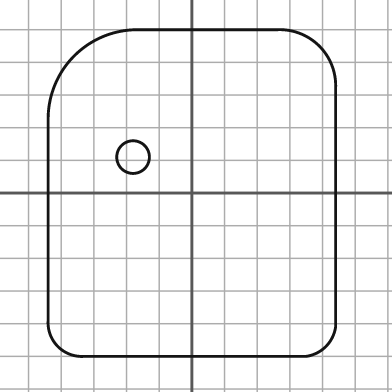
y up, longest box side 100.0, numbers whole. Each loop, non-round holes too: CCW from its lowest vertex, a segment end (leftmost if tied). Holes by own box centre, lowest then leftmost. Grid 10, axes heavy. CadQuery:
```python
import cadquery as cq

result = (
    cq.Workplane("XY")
    .moveTo(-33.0, -50.0)
    .lineTo(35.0, -50.0)
    .threePointArc((41.0, -47.0), (44.0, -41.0))
    .lineTo(44.0, 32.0)
    .threePointArc((39.0, 45.0), (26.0, 50.0))
    .lineTo(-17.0, 50.0)
    .threePointArc((-36.0, 42.0), (-44.0, 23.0))
    .lineTo(-44.0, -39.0)
    .threePointArc((-41.0, -47.0), (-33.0, -50.0))
    .close()
    .moveTo(-18.0, 11.0)
    .circle(5.0)
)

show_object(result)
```